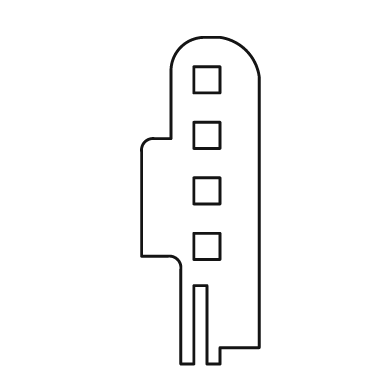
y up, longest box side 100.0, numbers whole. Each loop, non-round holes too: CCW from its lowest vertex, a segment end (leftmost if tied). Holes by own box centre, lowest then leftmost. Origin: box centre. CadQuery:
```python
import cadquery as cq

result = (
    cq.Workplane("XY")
    .moveTo(-6.0, -50.0)
    .lineTo(-2.0, -50.0)
    .lineTo(-2.0, -26.0)
    .lineTo(2.0, -26.0)
    .lineTo(2.0, -50.0)
    .lineTo(6.0, -50.0)
    .lineTo(6.0, -45.0)
    .lineTo(18.0, -45.0)
    .lineTo(18.0, 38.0)
    .threePointArc((14.0, 46.0), (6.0, 50.0))
    .lineTo(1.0, 50.0)
    .threePointArc((-6.0, 47.0), (-9.0, 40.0))
    .lineTo(-9.0, 19.0)
    .lineTo(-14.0, 19.0)
    .threePointArc((-17.0, 18.0), (-18.0, 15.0))
    .lineTo(-18.0, -17.0)
    .lineTo(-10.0, -17.0)
    .threePointArc((-7.0, -18.0), (-6.0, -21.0))
    .close()
    .moveTo(-2.0, -18.0)
    .lineTo(6.0, -18.0)
    .lineTo(6.0, -10.0)
    .lineTo(-2.0, -10.0)
    .close()
    .moveTo(-2.0, -1.0)
    .lineTo(6.0, -1.0)
    .lineTo(6.0, 7.0)
    .lineTo(-2.0, 7.0)
    .close()
    .moveTo(-2.0, 16.0)
    .lineTo(6.0, 16.0)
    .lineTo(6.0, 24.0)
    .lineTo(-2.0, 24.0)
    .close()
    .moveTo(-2.0, 33.0)
    .lineTo(6.0, 33.0)
    .lineTo(6.0, 41.0)
    .lineTo(-2.0, 41.0)
    .close()
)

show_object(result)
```